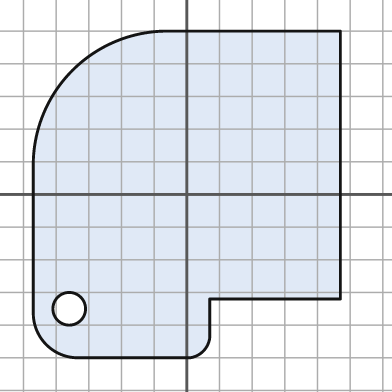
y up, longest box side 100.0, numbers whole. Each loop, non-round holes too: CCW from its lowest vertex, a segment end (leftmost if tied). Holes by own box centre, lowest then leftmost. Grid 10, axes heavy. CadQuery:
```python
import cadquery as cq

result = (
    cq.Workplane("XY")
    .moveTo(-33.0, -50.0)
    .lineTo(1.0, -50.0)
    .threePointArc((5.0, -48.0), (7.0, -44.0))
    .lineTo(7.0, -32.0)
    .lineTo(47.0, -32.0)
    .lineTo(47.0, 50.0)
    .lineTo(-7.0, 50.0)
    .threePointArc((-35.0, 38.0), (-47.0, 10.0))
    .lineTo(-47.0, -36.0)
    .threePointArc((-43.0, -46.0), (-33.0, -50.0))
    .close()
    .moveTo(-36.0, -35.0)
    .circle(5.0)
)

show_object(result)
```